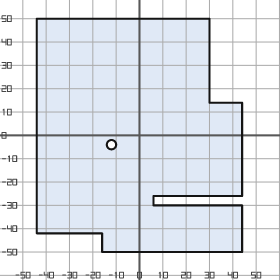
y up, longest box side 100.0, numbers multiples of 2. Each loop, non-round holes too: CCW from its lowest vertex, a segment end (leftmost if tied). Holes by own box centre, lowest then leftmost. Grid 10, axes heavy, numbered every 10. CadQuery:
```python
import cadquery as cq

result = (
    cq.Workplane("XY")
    .moveTo(-16.0, -50.0)
    .lineTo(44.0, -50.0)
    .lineTo(44.0, -30.0)
    .lineTo(6.0, -30.0)
    .lineTo(6.0, -26.0)
    .lineTo(44.0, -26.0)
    .lineTo(44.0, 14.0)
    .lineTo(30.0, 14.0)
    .lineTo(30.0, 50.0)
    .lineTo(-44.0, 50.0)
    .lineTo(-44.0, -42.0)
    .lineTo(-16.0, -42.0)
    .close()
    .moveTo(-12.0, -4.0)
    .circle(2.0)
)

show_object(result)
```